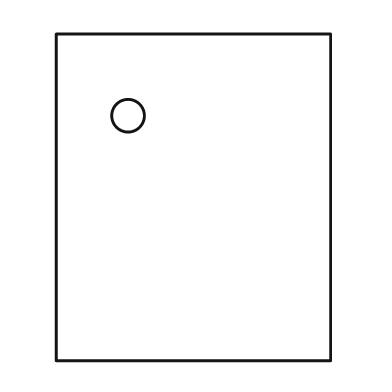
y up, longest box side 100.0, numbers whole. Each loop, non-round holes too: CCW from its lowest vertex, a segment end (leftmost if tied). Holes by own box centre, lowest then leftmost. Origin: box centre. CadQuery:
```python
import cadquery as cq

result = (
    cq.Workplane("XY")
    .moveTo(-42.0, -50.0)
    .lineTo(42.0, -50.0)
    .lineTo(42.0, 50.0)
    .lineTo(-42.0, 50.0)
    .close()
    .moveTo(-20.0, 25.0)
    .circle(5.0)
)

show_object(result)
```